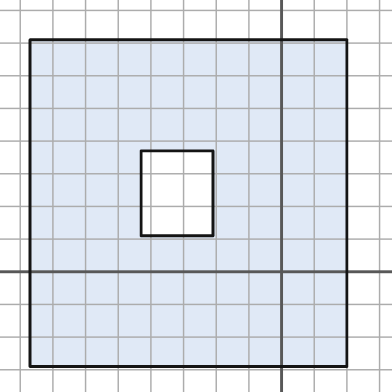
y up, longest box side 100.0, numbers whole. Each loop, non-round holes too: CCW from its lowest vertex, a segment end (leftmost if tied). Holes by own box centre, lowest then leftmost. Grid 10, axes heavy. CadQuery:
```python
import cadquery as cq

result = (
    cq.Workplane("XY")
    .moveTo(-77.0, -29.0)
    .lineTo(20.0, -29.0)
    .lineTo(20.0, 71.0)
    .lineTo(-77.0, 71.0)
    .close()
    .moveTo(-43.0, 11.0)
    .lineTo(-21.0, 11.0)
    .lineTo(-21.0, 37.0)
    .lineTo(-43.0, 37.0)
    .close()
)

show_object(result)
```